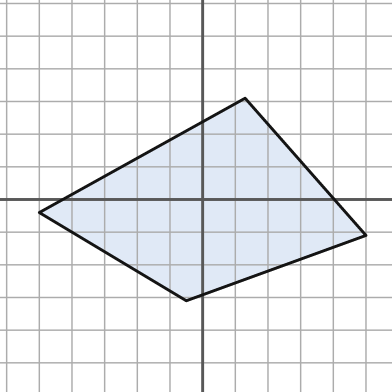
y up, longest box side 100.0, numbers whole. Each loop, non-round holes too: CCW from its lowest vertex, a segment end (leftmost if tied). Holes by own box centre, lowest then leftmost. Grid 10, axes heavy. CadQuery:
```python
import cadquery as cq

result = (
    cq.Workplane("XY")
    .moveTo(-5.0, -31.0)
    .lineTo(50.0, -11.0)
    .lineTo(13.0, 31.0)
    .lineTo(-50.0, -4.0)
    .close()
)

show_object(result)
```